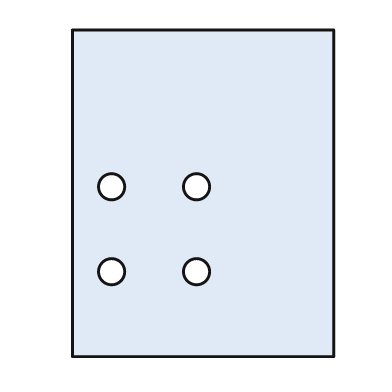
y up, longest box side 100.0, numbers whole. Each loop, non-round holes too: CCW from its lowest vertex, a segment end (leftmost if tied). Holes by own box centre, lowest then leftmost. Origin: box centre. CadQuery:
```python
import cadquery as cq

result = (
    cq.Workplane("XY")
    .moveTo(-40.0, -50.0)
    .lineTo(40.0, -50.0)
    .lineTo(40.0, 50.0)
    .lineTo(-40.0, 50.0)
    .close()
    .moveTo(-28.0, -24.0)
    .circle(4.0)
    .moveTo(-2.0, -24.0)
    .circle(4.0)
    .moveTo(-28.0, 2.0)
    .circle(4.0)
    .moveTo(-2.0, 2.0)
    .circle(4.0)
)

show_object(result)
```